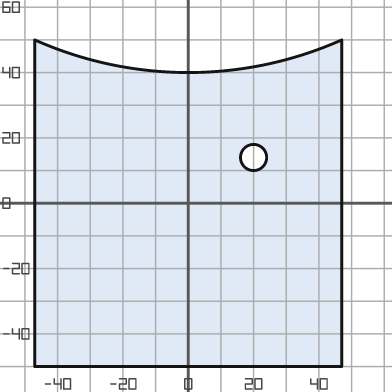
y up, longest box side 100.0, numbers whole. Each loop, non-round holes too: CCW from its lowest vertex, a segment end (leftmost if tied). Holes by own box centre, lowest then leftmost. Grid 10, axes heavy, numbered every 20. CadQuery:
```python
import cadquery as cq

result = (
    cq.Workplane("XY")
    .moveTo(-47.0, -50.0)
    .lineTo(47.0, -50.0)
    .lineTo(47.0, 50.0)
    .threePointArc((0.0, 40.0), (-47.0, 50.0))
    .close()
    .moveTo(20.0, 14.0)
    .circle(4.0)
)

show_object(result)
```